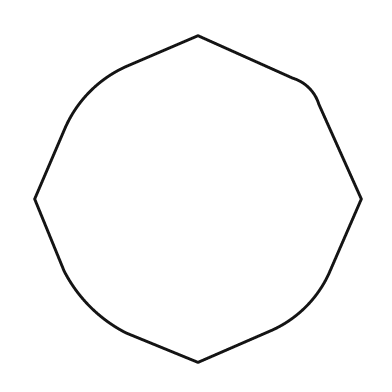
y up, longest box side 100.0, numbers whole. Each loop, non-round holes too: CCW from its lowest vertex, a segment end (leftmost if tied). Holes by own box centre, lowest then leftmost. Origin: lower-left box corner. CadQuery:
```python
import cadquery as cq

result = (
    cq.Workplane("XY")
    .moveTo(50.0, 0.0)
    .lineTo(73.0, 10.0)
    .threePointArc((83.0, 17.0), (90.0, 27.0))
    .lineTo(100.0, 50.0)
    .lineTo(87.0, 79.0)
    .threePointArc((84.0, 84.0), (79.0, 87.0))
    .lineTo(50.0, 100.0)
    .lineTo(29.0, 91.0)
    .threePointArc((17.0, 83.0), (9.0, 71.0))
    .lineTo(0.0, 50.0)
    .lineTo(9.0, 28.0)
    .threePointArc((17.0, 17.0), (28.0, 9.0))
    .close()
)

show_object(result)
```